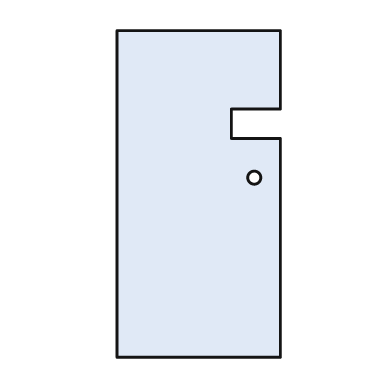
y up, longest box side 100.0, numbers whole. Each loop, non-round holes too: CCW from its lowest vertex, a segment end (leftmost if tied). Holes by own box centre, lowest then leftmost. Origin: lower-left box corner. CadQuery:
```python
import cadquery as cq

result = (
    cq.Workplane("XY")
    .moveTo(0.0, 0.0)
    .lineTo(50.0, 0.0)
    .lineTo(50.0, 67.0)
    .lineTo(35.0, 67.0)
    .lineTo(35.0, 76.0)
    .lineTo(50.0, 76.0)
    .lineTo(50.0, 100.0)
    .lineTo(0.0, 100.0)
    .close()
    .moveTo(42.0, 55.0)
    .circle(2.0)
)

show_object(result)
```